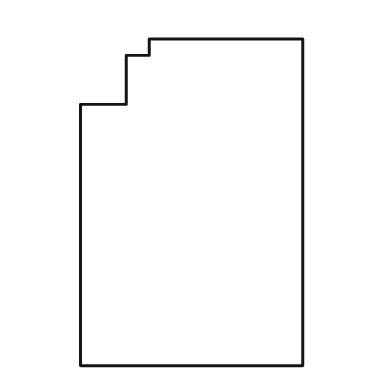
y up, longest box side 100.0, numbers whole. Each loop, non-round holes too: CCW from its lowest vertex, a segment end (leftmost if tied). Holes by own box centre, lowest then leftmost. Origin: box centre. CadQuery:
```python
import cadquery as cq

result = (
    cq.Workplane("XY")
    .moveTo(-34.0, -50.0)
    .lineTo(34.0, -50.0)
    .lineTo(34.0, 50.0)
    .lineTo(-13.0, 50.0)
    .lineTo(-13.0, 45.0)
    .lineTo(-20.0, 45.0)
    .lineTo(-20.0, 30.0)
    .lineTo(-34.0, 30.0)
    .close()
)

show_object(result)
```